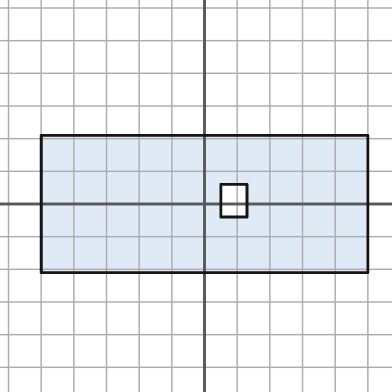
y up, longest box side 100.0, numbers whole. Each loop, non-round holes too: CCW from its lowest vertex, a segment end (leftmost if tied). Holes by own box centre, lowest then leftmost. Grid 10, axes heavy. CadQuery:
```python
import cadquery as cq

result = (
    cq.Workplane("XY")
    .moveTo(-50.0, -21.0)
    .lineTo(50.0, -21.0)
    .lineTo(50.0, 21.0)
    .lineTo(-50.0, 21.0)
    .close()
    .moveTo(5.0, -4.0)
    .lineTo(13.0, -4.0)
    .lineTo(13.0, 6.0)
    .lineTo(5.0, 6.0)
    .close()
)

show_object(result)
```